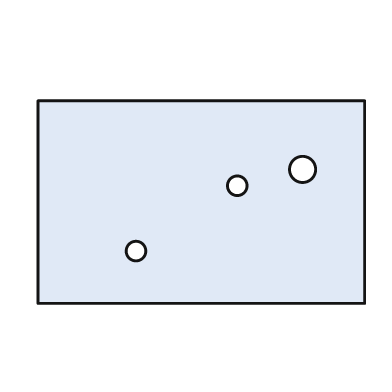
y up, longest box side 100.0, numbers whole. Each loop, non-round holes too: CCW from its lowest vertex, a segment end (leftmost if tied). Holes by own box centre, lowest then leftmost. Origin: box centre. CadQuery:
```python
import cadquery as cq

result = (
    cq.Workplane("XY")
    .moveTo(-50.0, -31.0)
    .lineTo(50.0, -31.0)
    .lineTo(50.0, 31.0)
    .lineTo(-50.0, 31.0)
    .close()
    .moveTo(-20.0, -15.0)
    .circle(3.0)
    .moveTo(11.0, 5.0)
    .circle(3.0)
    .moveTo(31.0, 10.0)
    .circle(4.0)
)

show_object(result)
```